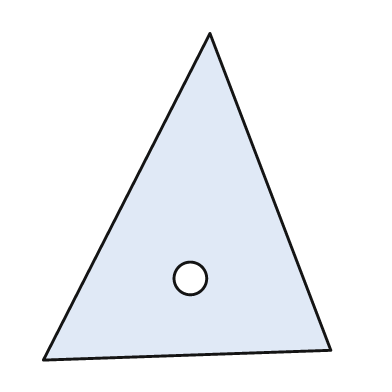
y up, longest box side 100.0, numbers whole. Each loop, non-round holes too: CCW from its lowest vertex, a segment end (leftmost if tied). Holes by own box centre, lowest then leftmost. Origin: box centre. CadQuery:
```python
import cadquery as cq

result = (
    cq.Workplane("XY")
    .moveTo(-44.0, -50.0)
    .lineTo(44.0, -47.0)
    .lineTo(7.0, 50.0)
    .close()
    .moveTo(1.0, -25.0)
    .circle(5.0)
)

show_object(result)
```